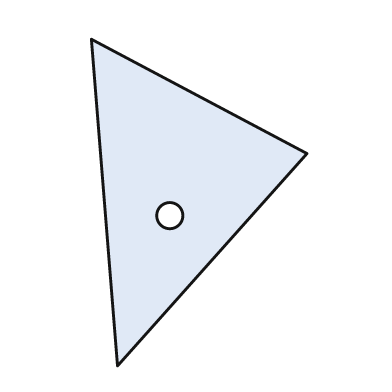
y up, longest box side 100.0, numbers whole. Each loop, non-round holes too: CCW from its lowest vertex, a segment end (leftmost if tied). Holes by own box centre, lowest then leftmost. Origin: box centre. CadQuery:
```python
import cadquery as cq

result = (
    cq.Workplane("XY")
    .moveTo(-25.0, -50.0)
    .lineTo(33.0, 15.0)
    .lineTo(-33.0, 50.0)
    .close()
    .moveTo(-9.0, -4.0)
    .circle(4.0)
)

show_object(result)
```